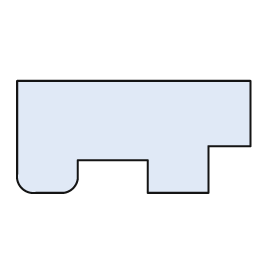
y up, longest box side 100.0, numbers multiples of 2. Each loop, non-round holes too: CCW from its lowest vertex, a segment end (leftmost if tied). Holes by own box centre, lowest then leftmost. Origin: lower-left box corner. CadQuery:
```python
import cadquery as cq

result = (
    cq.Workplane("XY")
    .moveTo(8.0, 0.0)
    .lineTo(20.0, 0.0)
    .threePointArc((24.0, 2.0), (26.0, 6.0))
    .lineTo(26.0, 14.0)
    .lineTo(56.0, 14.0)
    .lineTo(56.0, 0.0)
    .lineTo(82.0, 0.0)
    .lineTo(82.0, 20.0)
    .lineTo(100.0, 20.0)
    .lineTo(100.0, 48.0)
    .lineTo(0.0, 48.0)
    .lineTo(0.0, 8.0)
    .threePointArc((2.0, 2.0), (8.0, 0.0))
    .close()
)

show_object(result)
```